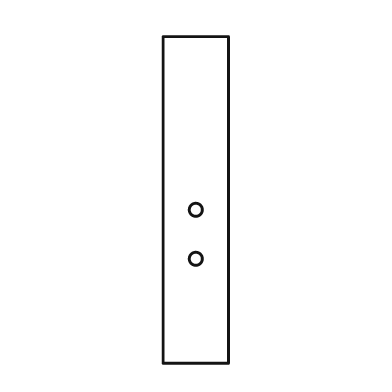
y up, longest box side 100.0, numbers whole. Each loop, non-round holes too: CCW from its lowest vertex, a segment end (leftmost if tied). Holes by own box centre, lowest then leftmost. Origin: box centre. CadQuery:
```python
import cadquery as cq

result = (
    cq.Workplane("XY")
    .moveTo(-10.0, -50.0)
    .lineTo(10.0, -50.0)
    .lineTo(10.0, 50.0)
    .lineTo(-10.0, 50.0)
    .close()
    .moveTo(0.0, -18.0)
    .circle(2.0)
    .moveTo(0.0, -3.0)
    .circle(2.0)
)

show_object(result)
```